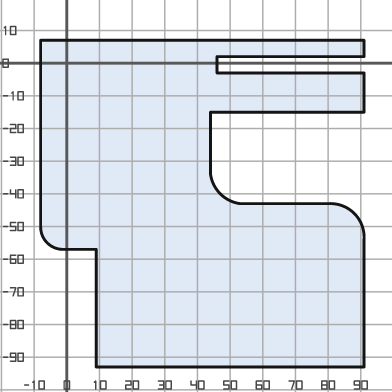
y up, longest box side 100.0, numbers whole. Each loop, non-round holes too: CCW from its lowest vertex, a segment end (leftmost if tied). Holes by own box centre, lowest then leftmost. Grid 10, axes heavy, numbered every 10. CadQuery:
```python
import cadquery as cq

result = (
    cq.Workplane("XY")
    .moveTo(9.0, -93.0)
    .lineTo(91.0, -93.0)
    .lineTo(91.0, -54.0)
    .threePointArc((88.0, -46.0), (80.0, -43.0))
    .lineTo(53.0, -43.0)
    .threePointArc((47.0, -40.0), (44.0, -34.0))
    .lineTo(44.0, -15.0)
    .lineTo(91.0, -15.0)
    .lineTo(91.0, -3.0)
    .lineTo(46.0, -3.0)
    .lineTo(46.0, 2.0)
    .lineTo(91.0, 2.0)
    .lineTo(91.0, 7.0)
    .lineTo(-8.0, 7.0)
    .lineTo(-8.0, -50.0)
    .threePointArc((-6.0, -55.0), (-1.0, -57.0))
    .lineTo(9.0, -57.0)
    .close()
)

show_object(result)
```